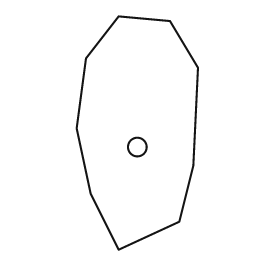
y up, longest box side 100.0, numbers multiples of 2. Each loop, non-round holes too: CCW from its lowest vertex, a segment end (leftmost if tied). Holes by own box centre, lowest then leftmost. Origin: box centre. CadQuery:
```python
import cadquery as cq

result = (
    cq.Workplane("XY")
    .moveTo(-8.0, -50.0)
    .lineTo(18.0, -38.0)
    .lineTo(24.0, -14.0)
    .lineTo(26.0, 28.0)
    .lineTo(14.0, 48.0)
    .lineTo(-8.0, 50.0)
    .lineTo(-22.0, 32.0)
    .lineTo(-26.0, 2.0)
    .lineTo(-20.0, -26.0)
    .close()
    .moveTo(0.0, -6.0)
    .circle(4.0)
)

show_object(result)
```